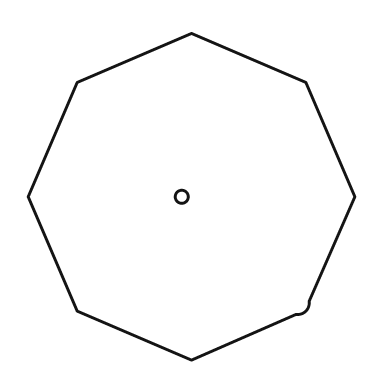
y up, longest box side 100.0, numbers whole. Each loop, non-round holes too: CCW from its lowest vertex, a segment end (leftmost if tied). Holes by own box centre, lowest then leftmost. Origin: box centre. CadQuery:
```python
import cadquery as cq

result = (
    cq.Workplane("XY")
    .moveTo(0.0, -50.0)
    .lineTo(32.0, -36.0)
    .threePointArc((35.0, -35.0), (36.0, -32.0))
    .lineTo(50.0, 0.0)
    .lineTo(35.0, 35.0)
    .lineTo(0.0, 50.0)
    .lineTo(-35.0, 35.0)
    .lineTo(-50.0, 0.0)
    .lineTo(-35.0, -35.0)
    .close()
    .moveTo(-3.0, 0.0)
    .circle(2.0)
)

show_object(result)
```